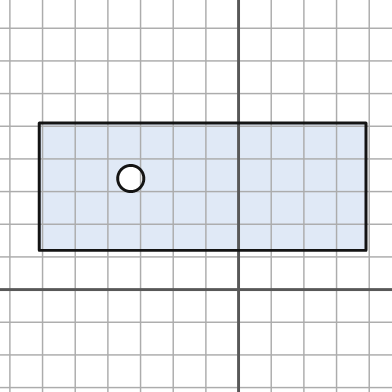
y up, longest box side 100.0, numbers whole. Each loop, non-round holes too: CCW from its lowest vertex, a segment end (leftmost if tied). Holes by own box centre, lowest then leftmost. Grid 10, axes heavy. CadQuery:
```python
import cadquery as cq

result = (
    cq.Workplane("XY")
    .moveTo(-61.0, 12.0)
    .lineTo(39.0, 12.0)
    .lineTo(39.0, 51.0)
    .lineTo(-61.0, 51.0)
    .close()
    .moveTo(-33.0, 34.0)
    .circle(4.0)
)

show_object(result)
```